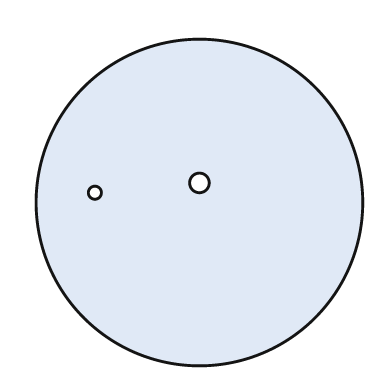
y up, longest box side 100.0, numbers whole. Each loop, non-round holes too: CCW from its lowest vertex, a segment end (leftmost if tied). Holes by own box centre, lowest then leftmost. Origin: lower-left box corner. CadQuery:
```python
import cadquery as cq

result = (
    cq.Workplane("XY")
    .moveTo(50.0, 50.0)
    .circle(50.0)
    .moveTo(18.0, 53.0)
    .circle(2.0)
    .moveTo(50.0, 56.0)
    .circle(3.0)
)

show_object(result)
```